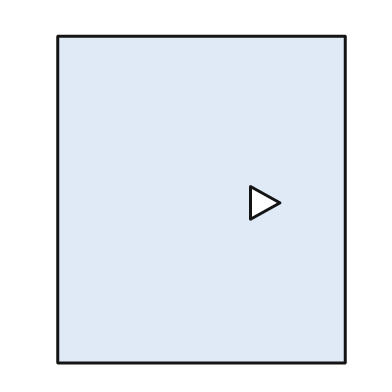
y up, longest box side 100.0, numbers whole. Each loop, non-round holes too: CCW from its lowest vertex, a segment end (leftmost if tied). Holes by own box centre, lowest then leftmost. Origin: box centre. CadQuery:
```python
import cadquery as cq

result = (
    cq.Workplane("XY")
    .moveTo(-44.0, -50.0)
    .lineTo(44.0, -50.0)
    .lineTo(44.0, 50.0)
    .lineTo(-44.0, 50.0)
    .close()
    .moveTo(15.0, -6.0)
    .lineTo(24.0, -1.0)
    .lineTo(15.0, 4.0)
    .close()
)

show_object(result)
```